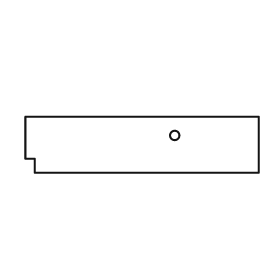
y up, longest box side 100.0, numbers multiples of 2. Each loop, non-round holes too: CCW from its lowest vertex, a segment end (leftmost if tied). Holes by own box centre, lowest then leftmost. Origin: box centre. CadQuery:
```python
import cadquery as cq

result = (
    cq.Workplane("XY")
    .moveTo(-46.0, -12.0)
    .lineTo(50.0, -12.0)
    .lineTo(50.0, 12.0)
    .lineTo(-50.0, 12.0)
    .lineTo(-50.0, -6.0)
    .lineTo(-46.0, -6.0)
    .close()
    .moveTo(14.0, 4.0)
    .circle(2.0)
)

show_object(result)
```